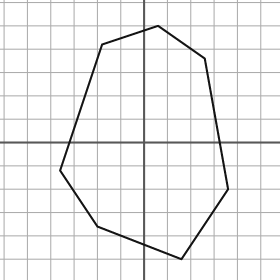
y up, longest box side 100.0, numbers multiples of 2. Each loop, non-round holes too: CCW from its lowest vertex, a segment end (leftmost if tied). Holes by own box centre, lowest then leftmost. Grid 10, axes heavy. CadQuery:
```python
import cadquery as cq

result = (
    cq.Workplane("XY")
    .moveTo(16.0, -50.0)
    .lineTo(36.0, -20.0)
    .lineTo(26.0, 36.0)
    .lineTo(6.0, 50.0)
    .lineTo(-18.0, 42.0)
    .lineTo(-36.0, -12.0)
    .lineTo(-20.0, -36.0)
    .close()
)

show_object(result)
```